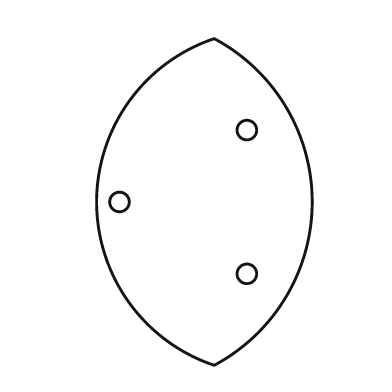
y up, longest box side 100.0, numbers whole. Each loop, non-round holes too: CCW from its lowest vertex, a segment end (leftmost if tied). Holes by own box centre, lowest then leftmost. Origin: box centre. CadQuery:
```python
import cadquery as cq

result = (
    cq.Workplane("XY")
    .moveTo(3.0, -50.0)
    .threePointArc((33.0, 0.0), (3.0, 50.0))
    .threePointArc((-33.0, 0.0), (3.0, -50.0))
    .close()
    .moveTo(13.0, -22.0)
    .circle(3.0)
    .moveTo(-26.0, 0.0)
    .circle(3.0)
    .moveTo(13.0, 22.0)
    .circle(3.0)
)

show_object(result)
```